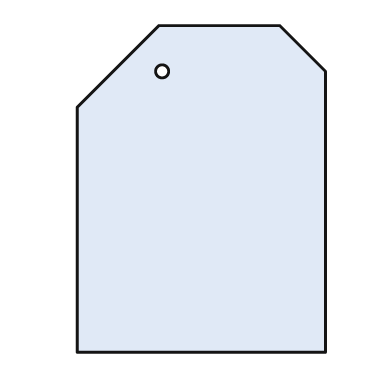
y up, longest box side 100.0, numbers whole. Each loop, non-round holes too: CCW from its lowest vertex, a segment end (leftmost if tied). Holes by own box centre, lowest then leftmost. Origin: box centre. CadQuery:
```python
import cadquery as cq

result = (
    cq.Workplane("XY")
    .moveTo(-38.0, -50.0)
    .lineTo(38.0, -50.0)
    .lineTo(38.0, 36.0)
    .lineTo(24.0, 50.0)
    .lineTo(-13.0, 50.0)
    .lineTo(-38.0, 25.0)
    .close()
    .moveTo(-12.0, 36.0)
    .circle(2.0)
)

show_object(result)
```